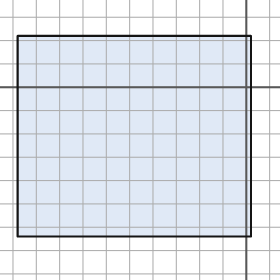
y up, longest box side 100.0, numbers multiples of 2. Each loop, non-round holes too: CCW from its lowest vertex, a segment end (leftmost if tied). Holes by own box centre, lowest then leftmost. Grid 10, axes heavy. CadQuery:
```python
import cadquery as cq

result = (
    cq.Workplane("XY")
    .moveTo(-98.0, -64.0)
    .lineTo(2.0, -64.0)
    .lineTo(2.0, 22.0)
    .lineTo(-98.0, 22.0)
    .close()
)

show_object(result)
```